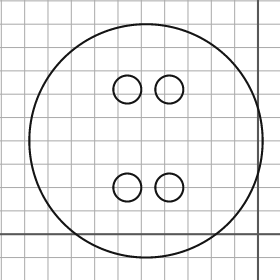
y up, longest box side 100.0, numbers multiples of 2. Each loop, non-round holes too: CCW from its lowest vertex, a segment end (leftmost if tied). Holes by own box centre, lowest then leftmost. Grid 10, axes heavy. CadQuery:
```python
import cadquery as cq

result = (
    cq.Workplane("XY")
    .moveTo(-48.0, 40.0)
    .circle(50.0)
    .moveTo(-56.0, 20.0)
    .circle(6.0)
    .moveTo(-38.0, 20.0)
    .circle(6.0)
    .moveTo(-56.0, 62.0)
    .circle(6.0)
    .moveTo(-38.0, 62.0)
    .circle(6.0)
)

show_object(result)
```